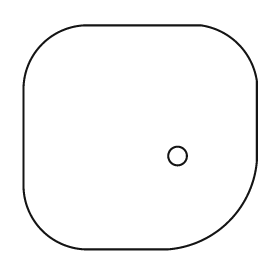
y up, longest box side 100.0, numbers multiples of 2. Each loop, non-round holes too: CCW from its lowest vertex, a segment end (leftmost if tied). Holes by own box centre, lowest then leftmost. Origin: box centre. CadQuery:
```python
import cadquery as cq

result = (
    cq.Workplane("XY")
    .moveTo(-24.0, -48.0)
    .lineTo(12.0, -48.0)
    .threePointArc((38.0, -36.0), (50.0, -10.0))
    .lineTo(50.0, 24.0)
    .threePointArc((42.0, 40.0), (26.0, 48.0))
    .lineTo(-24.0, 48.0)
    .threePointArc((-42.0, 40.0), (-50.0, 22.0))
    .lineTo(-50.0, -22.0)
    .threePointArc((-42.0, -40.0), (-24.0, -48.0))
    .close()
    .moveTo(16.0, -8.0)
    .circle(4.0)
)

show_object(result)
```